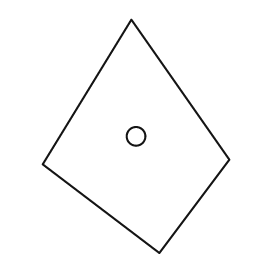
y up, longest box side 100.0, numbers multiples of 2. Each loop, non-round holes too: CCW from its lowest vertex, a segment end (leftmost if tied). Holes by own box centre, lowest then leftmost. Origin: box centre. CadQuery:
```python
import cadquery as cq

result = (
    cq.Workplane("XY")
    .moveTo(10.0, -50.0)
    .lineTo(40.0, -10.0)
    .lineTo(-2.0, 50.0)
    .lineTo(-40.0, -12.0)
    .close()
    .moveTo(0.0, 0.0)
    .circle(4.0)
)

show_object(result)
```